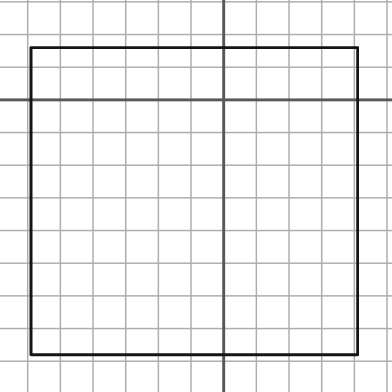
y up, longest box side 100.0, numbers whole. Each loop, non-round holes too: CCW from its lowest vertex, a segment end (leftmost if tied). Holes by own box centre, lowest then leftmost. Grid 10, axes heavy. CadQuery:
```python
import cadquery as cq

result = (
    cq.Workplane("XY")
    .moveTo(-59.0, -78.0)
    .lineTo(41.0, -78.0)
    .lineTo(41.0, 16.0)
    .lineTo(-59.0, 16.0)
    .close()
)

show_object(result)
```